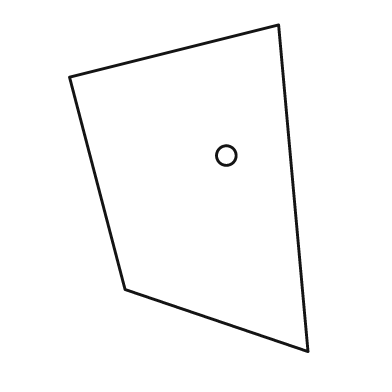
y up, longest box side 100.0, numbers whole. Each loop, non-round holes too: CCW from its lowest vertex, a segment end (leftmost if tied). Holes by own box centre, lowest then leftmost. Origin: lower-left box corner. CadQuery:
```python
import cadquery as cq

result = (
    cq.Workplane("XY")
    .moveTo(73.0, 0.0)
    .lineTo(64.0, 100.0)
    .lineTo(0.0, 84.0)
    .lineTo(17.0, 19.0)
    .close()
    .moveTo(48.0, 60.0)
    .circle(3.0)
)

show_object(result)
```